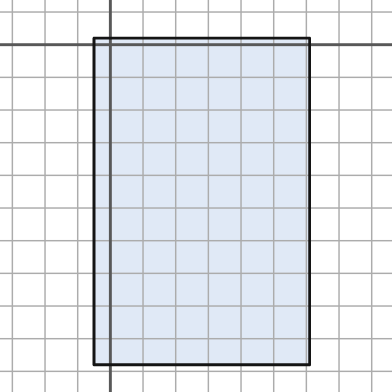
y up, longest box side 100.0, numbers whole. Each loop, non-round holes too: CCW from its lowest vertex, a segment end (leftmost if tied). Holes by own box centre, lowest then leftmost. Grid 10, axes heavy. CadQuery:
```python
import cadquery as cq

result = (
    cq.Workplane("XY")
    .moveTo(-5.0, -98.0)
    .lineTo(61.0, -98.0)
    .lineTo(61.0, 2.0)
    .lineTo(-5.0, 2.0)
    .close()
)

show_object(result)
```